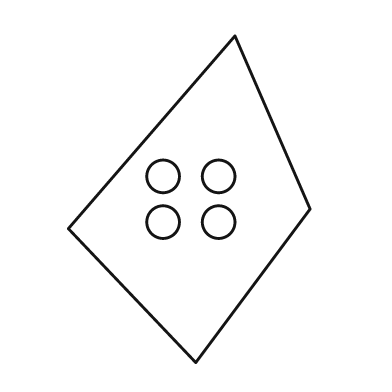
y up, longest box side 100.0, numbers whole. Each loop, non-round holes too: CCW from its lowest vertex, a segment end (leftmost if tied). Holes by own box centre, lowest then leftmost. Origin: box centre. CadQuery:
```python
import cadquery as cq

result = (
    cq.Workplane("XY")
    .moveTo(2.0, -50.0)
    .lineTo(37.0, -3.0)
    .lineTo(14.0, 50.0)
    .lineTo(-37.0, -9.0)
    .close()
    .moveTo(-8.0, -7.0)
    .circle(5.0)
    .moveTo(9.0, -7.0)
    .circle(5.0)
    .moveTo(-8.0, 7.0)
    .circle(5.0)
    .moveTo(9.0, 7.0)
    .circle(5.0)
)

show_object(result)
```